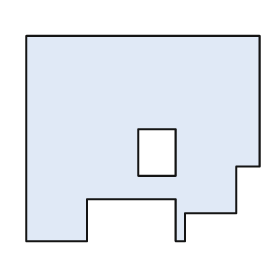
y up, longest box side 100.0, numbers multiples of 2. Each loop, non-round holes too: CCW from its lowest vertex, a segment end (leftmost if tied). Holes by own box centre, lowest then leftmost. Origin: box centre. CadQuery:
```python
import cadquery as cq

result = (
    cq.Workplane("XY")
    .moveTo(-50.0, -44.0)
    .lineTo(-24.0, -44.0)
    .lineTo(-24.0, -26.0)
    .lineTo(14.0, -26.0)
    .lineTo(14.0, -44.0)
    .lineTo(18.0, -44.0)
    .lineTo(18.0, -32.0)
    .lineTo(40.0, -32.0)
    .lineTo(40.0, -12.0)
    .lineTo(50.0, -12.0)
    .lineTo(50.0, 44.0)
    .lineTo(-50.0, 44.0)
    .close()
    .moveTo(-2.0, -16.0)
    .lineTo(14.0, -16.0)
    .lineTo(14.0, 4.0)
    .lineTo(-2.0, 4.0)
    .close()
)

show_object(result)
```